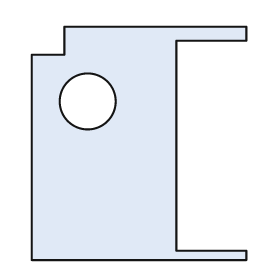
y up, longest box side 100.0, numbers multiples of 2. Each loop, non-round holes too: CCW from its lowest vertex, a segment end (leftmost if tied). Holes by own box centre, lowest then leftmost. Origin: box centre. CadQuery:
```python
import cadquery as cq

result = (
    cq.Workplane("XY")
    .moveTo(-46.0, -50.0)
    .lineTo(46.0, -50.0)
    .lineTo(46.0, -46.0)
    .lineTo(16.0, -46.0)
    .lineTo(16.0, 44.0)
    .lineTo(46.0, 44.0)
    .lineTo(46.0, 50.0)
    .lineTo(-32.0, 50.0)
    .lineTo(-32.0, 38.0)
    .lineTo(-46.0, 38.0)
    .close()
    .moveTo(-22.0, 18.0)
    .circle(12.0)
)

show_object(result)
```